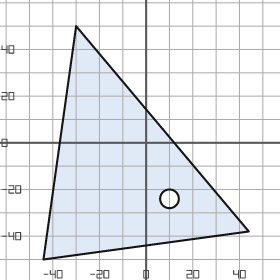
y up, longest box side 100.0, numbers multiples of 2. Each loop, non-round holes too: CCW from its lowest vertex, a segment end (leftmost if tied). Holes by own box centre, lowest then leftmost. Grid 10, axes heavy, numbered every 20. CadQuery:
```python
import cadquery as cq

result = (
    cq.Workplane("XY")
    .moveTo(-44.0, -50.0)
    .lineTo(44.0, -38.0)
    .lineTo(-30.0, 50.0)
    .close()
    .moveTo(10.0, -24.0)
    .circle(4.0)
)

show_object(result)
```